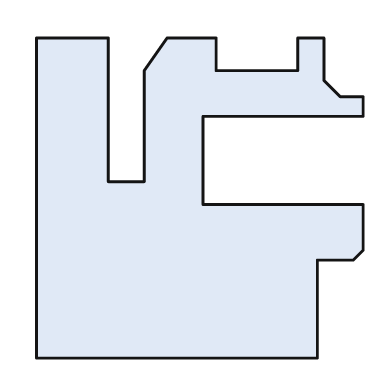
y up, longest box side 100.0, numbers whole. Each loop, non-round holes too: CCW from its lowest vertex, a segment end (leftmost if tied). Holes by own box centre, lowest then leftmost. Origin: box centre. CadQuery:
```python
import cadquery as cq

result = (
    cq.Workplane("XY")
    .moveTo(-50.0, -49.0)
    .lineTo(36.0, -49.0)
    .lineTo(36.0, -19.0)
    .lineTo(47.0, -19.0)
    .lineTo(50.0, -16.0)
    .lineTo(50.0, -2.0)
    .lineTo(1.0, -2.0)
    .lineTo(1.0, 25.0)
    .lineTo(50.0, 25.0)
    .lineTo(50.0, 31.0)
    .lineTo(43.0, 31.0)
    .lineTo(38.0, 36.0)
    .lineTo(38.0, 49.0)
    .lineTo(30.0, 49.0)
    .lineTo(30.0, 39.0)
    .lineTo(5.0, 39.0)
    .lineTo(5.0, 49.0)
    .lineTo(-10.0, 49.0)
    .lineTo(-17.0, 39.0)
    .lineTo(-17.0, 5.0)
    .lineTo(-28.0, 5.0)
    .lineTo(-28.0, 49.0)
    .lineTo(-50.0, 49.0)
    .close()
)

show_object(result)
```